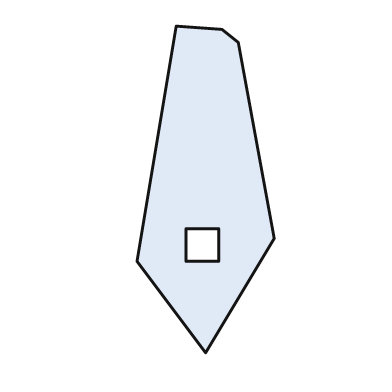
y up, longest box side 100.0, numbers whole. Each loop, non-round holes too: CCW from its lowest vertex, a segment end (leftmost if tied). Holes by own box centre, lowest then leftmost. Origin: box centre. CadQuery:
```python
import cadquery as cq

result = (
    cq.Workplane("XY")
    .moveTo(0.0, -50.0)
    .lineTo(21.0, -15.0)
    .lineTo(10.0, 45.0)
    .lineTo(5.0, 49.0)
    .lineTo(-9.0, 50.0)
    .lineTo(-21.0, -22.0)
    .close()
    .moveTo(-6.0, -22.0)
    .lineTo(4.0, -22.0)
    .lineTo(4.0, -12.0)
    .lineTo(-6.0, -12.0)
    .close()
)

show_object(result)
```